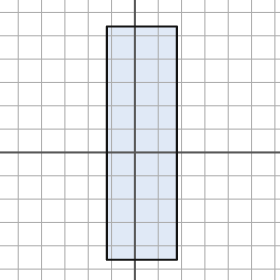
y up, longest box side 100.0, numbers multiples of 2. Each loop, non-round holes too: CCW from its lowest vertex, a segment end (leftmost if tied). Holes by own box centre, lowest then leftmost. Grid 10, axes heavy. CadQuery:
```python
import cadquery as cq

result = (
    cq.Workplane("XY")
    .moveTo(-12.0, -46.0)
    .lineTo(18.0, -46.0)
    .lineTo(18.0, 54.0)
    .lineTo(-12.0, 54.0)
    .close()
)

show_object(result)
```